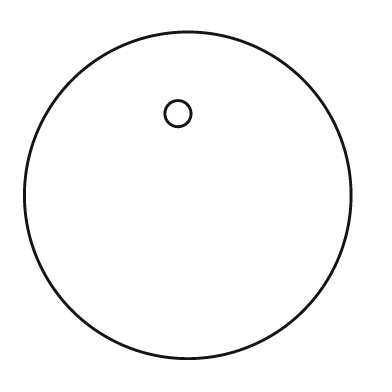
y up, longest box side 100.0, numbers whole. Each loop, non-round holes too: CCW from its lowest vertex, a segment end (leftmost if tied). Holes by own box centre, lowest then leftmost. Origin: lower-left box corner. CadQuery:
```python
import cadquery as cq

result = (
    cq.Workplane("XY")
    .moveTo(50.0, 50.0)
    .circle(50.0)
    .moveTo(47.0, 75.0)
    .circle(4.0)
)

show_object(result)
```